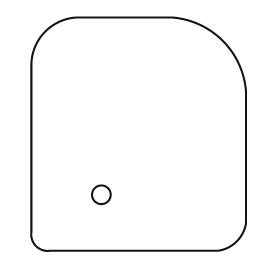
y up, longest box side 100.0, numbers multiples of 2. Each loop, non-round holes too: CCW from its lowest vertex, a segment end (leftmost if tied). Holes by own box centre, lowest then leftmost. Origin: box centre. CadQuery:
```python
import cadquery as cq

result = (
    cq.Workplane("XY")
    .moveTo(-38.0, -50.0)
    .lineTo(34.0, -50.0)
    .threePointArc((42.0, -46.0), (46.0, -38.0))
    .lineTo(46.0, 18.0)
    .threePointArc((36.0, 40.0), (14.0, 50.0))
    .lineTo(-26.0, 50.0)
    .threePointArc((-40.0, 44.0), (-46.0, 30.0))
    .lineTo(-46.0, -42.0)
    .threePointArc((-44.0, -48.0), (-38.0, -50.0))
    .close()
    .moveTo(-16.0, -26.0)
    .circle(4.0)
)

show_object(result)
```